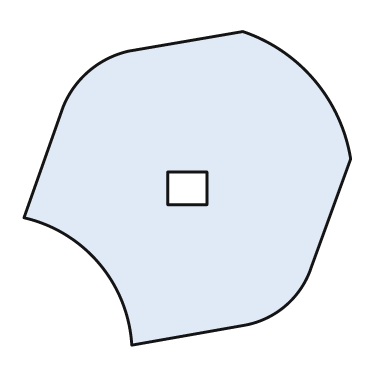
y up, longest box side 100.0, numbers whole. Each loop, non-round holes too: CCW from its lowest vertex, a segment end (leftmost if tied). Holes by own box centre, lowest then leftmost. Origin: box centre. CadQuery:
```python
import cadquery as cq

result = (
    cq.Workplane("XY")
    .moveTo(-17.0, -48.0)
    .lineTo(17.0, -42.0)
    .threePointArc((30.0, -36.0), (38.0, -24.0))
    .lineTo(50.0, 9.0)
    .threePointArc((39.0, 33.0), (17.0, 48.0))
    .lineTo(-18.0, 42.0)
    .threePointArc((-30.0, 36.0), (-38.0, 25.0))
    .lineTo(-50.0, -9.0)
    .threePointArc((-27.0, -23.0), (-17.0, -48.0))
    .close()
    .moveTo(-6.0, -5.0)
    .lineTo(6.0, -5.0)
    .lineTo(6.0, 5.0)
    .lineTo(-6.0, 5.0)
    .close()
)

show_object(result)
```